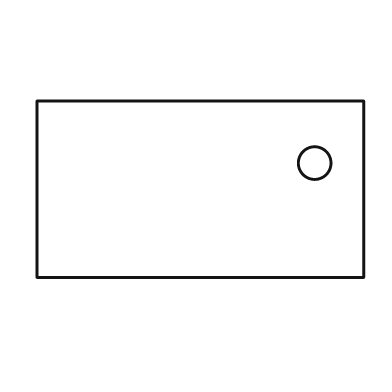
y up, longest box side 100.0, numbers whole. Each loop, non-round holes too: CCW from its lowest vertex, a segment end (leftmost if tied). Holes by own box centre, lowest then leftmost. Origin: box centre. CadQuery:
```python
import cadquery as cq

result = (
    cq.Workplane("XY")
    .moveTo(-50.0, -27.0)
    .lineTo(50.0, -27.0)
    .lineTo(50.0, 27.0)
    .lineTo(-50.0, 27.0)
    .close()
    .moveTo(35.0, 8.0)
    .circle(5.0)
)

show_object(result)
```